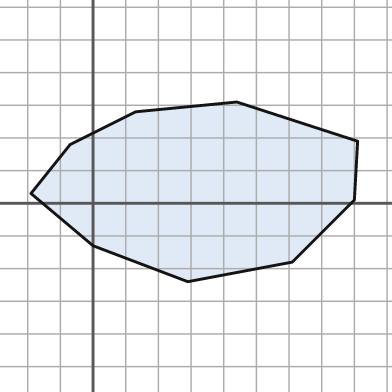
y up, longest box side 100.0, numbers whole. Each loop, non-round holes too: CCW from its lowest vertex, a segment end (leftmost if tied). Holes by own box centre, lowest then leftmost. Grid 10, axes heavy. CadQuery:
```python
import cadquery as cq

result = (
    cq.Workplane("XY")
    .moveTo(29.0, -24.0)
    .lineTo(61.0, -18.0)
    .lineTo(80.0, 1.0)
    .lineTo(81.0, 19.0)
    .lineTo(44.0, 31.0)
    .lineTo(13.0, 28.0)
    .lineTo(-7.0, 18.0)
    .lineTo(-19.0, 3.0)
    .lineTo(0.0, -13.0)
    .close()
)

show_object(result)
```